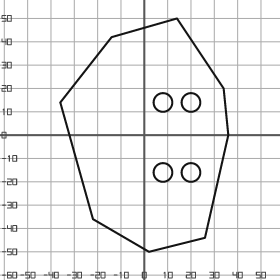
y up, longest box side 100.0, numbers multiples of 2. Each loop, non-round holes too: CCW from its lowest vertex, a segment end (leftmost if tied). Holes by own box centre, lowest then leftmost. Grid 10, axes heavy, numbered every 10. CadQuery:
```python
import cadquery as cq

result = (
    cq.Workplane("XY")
    .moveTo(2.0, -50.0)
    .lineTo(26.0, -44.0)
    .lineTo(36.0, 0.0)
    .lineTo(34.0, 20.0)
    .lineTo(14.0, 50.0)
    .lineTo(-14.0, 42.0)
    .lineTo(-36.0, 14.0)
    .lineTo(-22.0, -36.0)
    .close()
    .moveTo(8.0, -16.0)
    .circle(4.0)
    .moveTo(20.0, -16.0)
    .circle(4.0)
    .moveTo(8.0, 14.0)
    .circle(4.0)
    .moveTo(20.0, 14.0)
    .circle(4.0)
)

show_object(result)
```